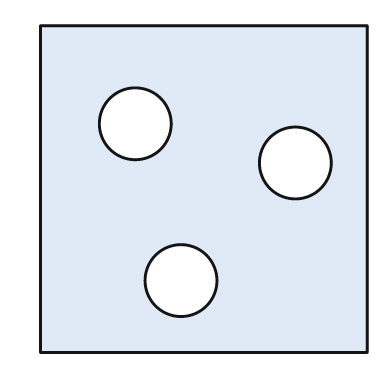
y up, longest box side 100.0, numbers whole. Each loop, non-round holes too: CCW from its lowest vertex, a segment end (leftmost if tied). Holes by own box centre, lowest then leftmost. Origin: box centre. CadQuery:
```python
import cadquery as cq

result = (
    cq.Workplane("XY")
    .moveTo(-50.0, -50.0)
    .lineTo(50.0, -50.0)
    .lineTo(50.0, 50.0)
    .lineTo(-50.0, 50.0)
    .close()
    .moveTo(-7.0, -28.0)
    .circle(11.0)
    .moveTo(28.0, 8.0)
    .circle(11.0)
    .moveTo(-21.0, 20.0)
    .circle(11.0)
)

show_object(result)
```